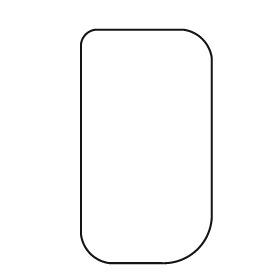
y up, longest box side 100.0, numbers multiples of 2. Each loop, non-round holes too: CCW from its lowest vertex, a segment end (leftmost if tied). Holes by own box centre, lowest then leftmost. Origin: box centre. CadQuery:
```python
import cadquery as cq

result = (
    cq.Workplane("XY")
    .moveTo(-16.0, -50.0)
    .lineTo(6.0, -50.0)
    .threePointArc((22.0, -44.0), (28.0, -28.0))
    .lineTo(28.0, 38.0)
    .threePointArc((24.0, 46.0), (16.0, 50.0))
    .lineTo(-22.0, 50.0)
    .threePointArc((-26.0, 48.0), (-28.0, 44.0))
    .lineTo(-28.0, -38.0)
    .threePointArc((-24.0, -46.0), (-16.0, -50.0))
    .close()
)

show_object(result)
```